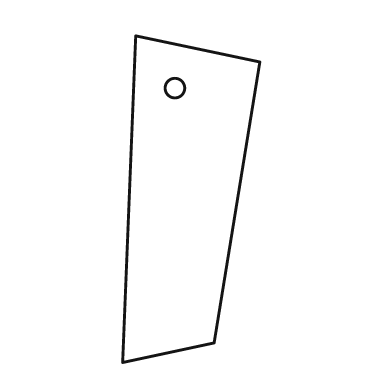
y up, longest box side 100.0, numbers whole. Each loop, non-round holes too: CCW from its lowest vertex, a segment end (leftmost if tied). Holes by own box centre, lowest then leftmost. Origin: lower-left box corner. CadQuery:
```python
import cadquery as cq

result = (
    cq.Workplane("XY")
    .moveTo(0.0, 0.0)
    .lineTo(28.0, 6.0)
    .lineTo(42.0, 92.0)
    .lineTo(4.0, 100.0)
    .close()
    .moveTo(16.0, 84.0)
    .circle(3.0)
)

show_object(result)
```